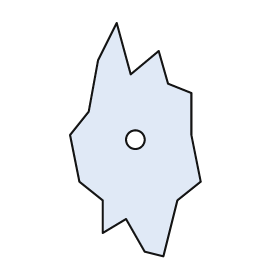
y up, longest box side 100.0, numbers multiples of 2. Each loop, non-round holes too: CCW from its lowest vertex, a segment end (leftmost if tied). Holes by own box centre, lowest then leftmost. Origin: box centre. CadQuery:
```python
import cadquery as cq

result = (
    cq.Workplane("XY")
    .moveTo(12.0, -50.0)
    .lineTo(18.0, -26.0)
    .lineTo(28.0, -18.0)
    .lineTo(24.0, 2.0)
    .lineTo(24.0, 20.0)
    .lineTo(14.0, 24.0)
    .lineTo(10.0, 38.0)
    .lineTo(-2.0, 28.0)
    .lineTo(-8.0, 50.0)
    .lineTo(-16.0, 34.0)
    .lineTo(-20.0, 12.0)
    .lineTo(-28.0, 2.0)
    .lineTo(-24.0, -18.0)
    .lineTo(-14.0, -26.0)
    .lineTo(-14.0, -40.0)
    .lineTo(-4.0, -34.0)
    .lineTo(4.0, -48.0)
    .close()
    .moveTo(0.0, 0.0)
    .circle(4.0)
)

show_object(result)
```